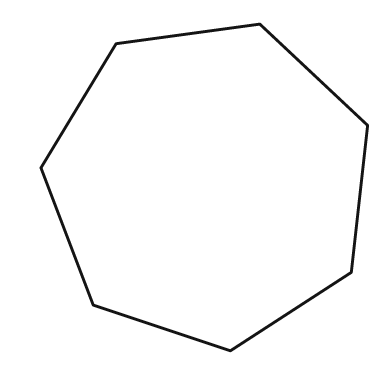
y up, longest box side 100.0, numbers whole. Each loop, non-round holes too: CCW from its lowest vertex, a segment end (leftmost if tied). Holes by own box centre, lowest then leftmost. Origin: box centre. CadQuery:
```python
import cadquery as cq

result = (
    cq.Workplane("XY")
    .moveTo(8.0, -50.0)
    .lineTo(45.0, -26.0)
    .lineTo(50.0, 19.0)
    .lineTo(17.0, 50.0)
    .lineTo(-27.0, 44.0)
    .lineTo(-50.0, 6.0)
    .lineTo(-34.0, -36.0)
    .close()
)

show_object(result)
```